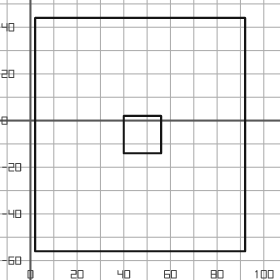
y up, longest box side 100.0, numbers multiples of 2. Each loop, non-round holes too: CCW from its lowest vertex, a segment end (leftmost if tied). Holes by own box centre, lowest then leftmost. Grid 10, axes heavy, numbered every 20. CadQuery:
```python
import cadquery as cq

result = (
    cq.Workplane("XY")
    .moveTo(2.0, -56.0)
    .lineTo(92.0, -56.0)
    .lineTo(92.0, 44.0)
    .lineTo(2.0, 44.0)
    .close()
    .moveTo(40.0, -14.0)
    .lineTo(56.0, -14.0)
    .lineTo(56.0, 2.0)
    .lineTo(40.0, 2.0)
    .close()
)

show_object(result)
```